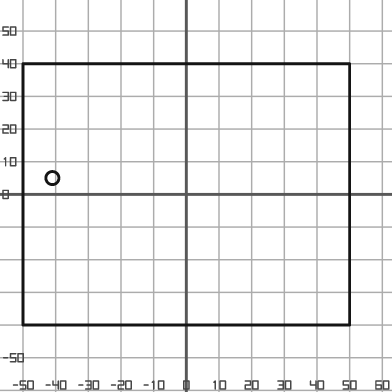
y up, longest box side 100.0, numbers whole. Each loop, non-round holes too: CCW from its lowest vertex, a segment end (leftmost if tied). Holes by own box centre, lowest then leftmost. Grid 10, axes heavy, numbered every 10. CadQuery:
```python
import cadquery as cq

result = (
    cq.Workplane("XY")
    .moveTo(-50.0, -40.0)
    .lineTo(50.0, -40.0)
    .lineTo(50.0, 40.0)
    .lineTo(-50.0, 40.0)
    .close()
    .moveTo(-41.0, 5.0)
    .circle(2.0)
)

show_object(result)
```